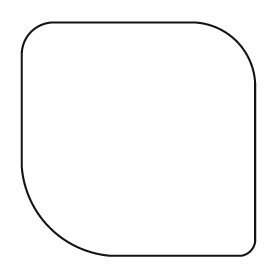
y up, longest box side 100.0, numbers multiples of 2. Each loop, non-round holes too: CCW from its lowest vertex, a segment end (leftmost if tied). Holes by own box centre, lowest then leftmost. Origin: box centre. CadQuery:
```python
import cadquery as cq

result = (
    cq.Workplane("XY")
    .moveTo(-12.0, -50.0)
    .lineTo(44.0, -50.0)
    .threePointArc((48.0, -48.0), (50.0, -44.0))
    .lineTo(50.0, 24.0)
    .threePointArc((42.0, 42.0), (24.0, 50.0))
    .lineTo(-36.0, 50.0)
    .threePointArc((-46.0, 46.0), (-50.0, 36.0))
    .lineTo(-50.0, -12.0)
    .threePointArc((-38.0, -38.0), (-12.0, -50.0))
    .close()
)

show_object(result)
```